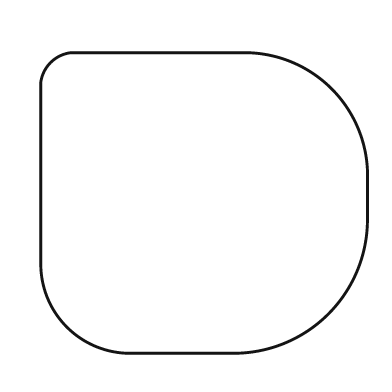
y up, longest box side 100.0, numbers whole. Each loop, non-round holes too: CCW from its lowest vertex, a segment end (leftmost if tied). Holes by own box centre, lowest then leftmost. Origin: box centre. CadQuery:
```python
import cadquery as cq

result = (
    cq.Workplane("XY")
    .moveTo(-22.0, -46.0)
    .lineTo(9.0, -46.0)
    .threePointArc((38.0, -34.0), (50.0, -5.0))
    .lineTo(50.0, 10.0)
    .threePointArc((39.0, 35.0), (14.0, 46.0))
    .lineTo(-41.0, 46.0)
    .threePointArc((-47.0, 43.0), (-50.0, 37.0))
    .lineTo(-50.0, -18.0)
    .threePointArc((-42.0, -38.0), (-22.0, -46.0))
    .close()
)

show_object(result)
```